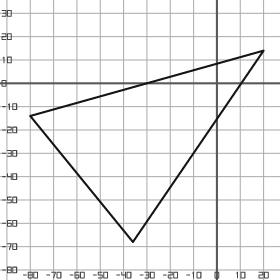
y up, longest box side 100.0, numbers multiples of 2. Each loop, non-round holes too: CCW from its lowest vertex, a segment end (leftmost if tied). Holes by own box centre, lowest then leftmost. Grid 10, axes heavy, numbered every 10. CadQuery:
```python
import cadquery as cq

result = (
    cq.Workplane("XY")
    .moveTo(-36.0, -68.0)
    .lineTo(20.0, 14.0)
    .lineTo(-80.0, -14.0)
    .close()
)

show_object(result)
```